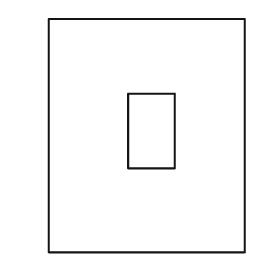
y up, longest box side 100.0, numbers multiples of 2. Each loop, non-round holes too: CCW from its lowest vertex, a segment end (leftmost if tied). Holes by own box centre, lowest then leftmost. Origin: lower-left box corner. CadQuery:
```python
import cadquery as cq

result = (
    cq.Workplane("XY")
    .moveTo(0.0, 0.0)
    .lineTo(84.0, 0.0)
    .lineTo(84.0, 100.0)
    .lineTo(0.0, 100.0)
    .close()
    .moveTo(34.0, 36.0)
    .lineTo(54.0, 36.0)
    .lineTo(54.0, 68.0)
    .lineTo(34.0, 68.0)
    .close()
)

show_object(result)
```